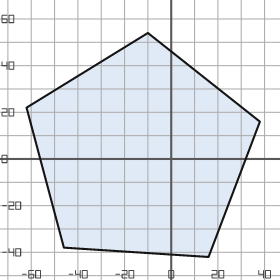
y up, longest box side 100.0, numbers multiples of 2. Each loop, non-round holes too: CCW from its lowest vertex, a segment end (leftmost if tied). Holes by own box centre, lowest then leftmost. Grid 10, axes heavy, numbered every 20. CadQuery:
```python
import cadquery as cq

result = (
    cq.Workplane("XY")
    .moveTo(16.0, -42.0)
    .lineTo(38.0, 16.0)
    .lineTo(-10.0, 54.0)
    .lineTo(-62.0, 22.0)
    .lineTo(-46.0, -38.0)
    .close()
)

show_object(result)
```